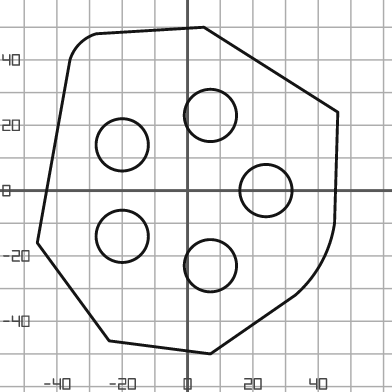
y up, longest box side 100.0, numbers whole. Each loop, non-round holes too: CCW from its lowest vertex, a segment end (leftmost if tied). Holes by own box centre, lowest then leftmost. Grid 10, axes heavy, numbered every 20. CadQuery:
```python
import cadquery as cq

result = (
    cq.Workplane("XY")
    .moveTo(7.0, -50.0)
    .lineTo(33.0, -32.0)
    .threePointArc((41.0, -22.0), (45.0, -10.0))
    .lineTo(46.0, 24.0)
    .lineTo(5.0, 50.0)
    .lineTo(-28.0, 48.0)
    .threePointArc((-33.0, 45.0), (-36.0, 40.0))
    .lineTo(-46.0, -16.0)
    .lineTo(-24.0, -46.0)
    .close()
    .moveTo(7.0, -23.0)
    .circle(8.0)
    .moveTo(-20.0, -14.0)
    .circle(8.0)
    .moveTo(24.0, 0.0)
    .circle(8.0)
    .moveTo(-20.0, 14.0)
    .circle(8.0)
    .moveTo(7.0, 23.0)
    .circle(8.0)
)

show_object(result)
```